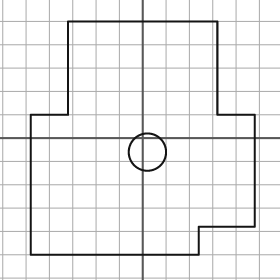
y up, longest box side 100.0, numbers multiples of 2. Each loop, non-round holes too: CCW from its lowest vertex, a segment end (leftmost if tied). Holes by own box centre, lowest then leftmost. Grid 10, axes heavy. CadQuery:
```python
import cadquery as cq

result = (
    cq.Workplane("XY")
    .moveTo(-48.0, -50.0)
    .lineTo(24.0, -50.0)
    .lineTo(24.0, -38.0)
    .lineTo(48.0, -38.0)
    .lineTo(48.0, 10.0)
    .lineTo(32.0, 10.0)
    .lineTo(32.0, 50.0)
    .lineTo(-32.0, 50.0)
    .lineTo(-32.0, 10.0)
    .lineTo(-48.0, 10.0)
    .close()
    .moveTo(2.0, -6.0)
    .circle(8.0)
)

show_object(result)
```